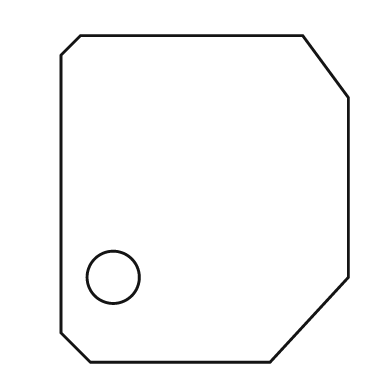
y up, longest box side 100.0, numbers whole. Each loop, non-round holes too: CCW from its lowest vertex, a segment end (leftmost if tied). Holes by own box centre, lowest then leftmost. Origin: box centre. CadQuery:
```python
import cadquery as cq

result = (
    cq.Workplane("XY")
    .moveTo(-35.0, -50.0)
    .lineTo(20.0, -50.0)
    .lineTo(44.0, -24.0)
    .lineTo(44.0, 31.0)
    .lineTo(30.0, 50.0)
    .lineTo(-38.0, 50.0)
    .lineTo(-44.0, 44.0)
    .lineTo(-44.0, -41.0)
    .close()
    .moveTo(-28.0, -24.0)
    .circle(8.0)
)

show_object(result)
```